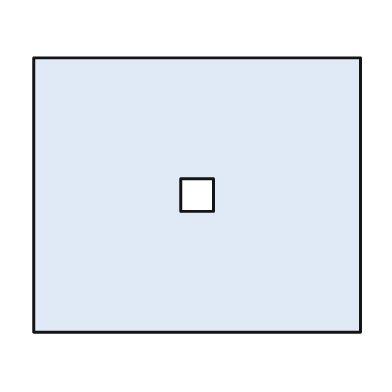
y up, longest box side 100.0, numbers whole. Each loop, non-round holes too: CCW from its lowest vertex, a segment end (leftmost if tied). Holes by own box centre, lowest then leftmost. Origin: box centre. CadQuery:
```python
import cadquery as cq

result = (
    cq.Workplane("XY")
    .moveTo(-50.0, -42.0)
    .lineTo(50.0, -42.0)
    .lineTo(50.0, 42.0)
    .lineTo(-50.0, 42.0)
    .close()
    .moveTo(-5.0, -5.0)
    .lineTo(5.0, -5.0)
    .lineTo(5.0, 5.0)
    .lineTo(-5.0, 5.0)
    .close()
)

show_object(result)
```